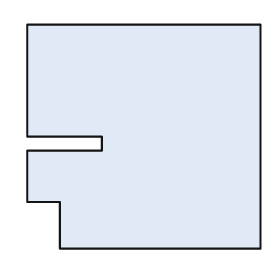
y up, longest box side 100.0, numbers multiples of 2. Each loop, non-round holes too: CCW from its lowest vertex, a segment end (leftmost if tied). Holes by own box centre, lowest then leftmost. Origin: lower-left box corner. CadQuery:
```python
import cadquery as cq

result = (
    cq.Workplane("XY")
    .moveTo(14.0, 0.0)
    .lineTo(100.0, 0.0)
    .lineTo(100.0, 96.0)
    .lineTo(0.0, 96.0)
    .lineTo(0.0, 48.0)
    .lineTo(32.0, 48.0)
    .lineTo(32.0, 42.0)
    .lineTo(0.0, 42.0)
    .lineTo(0.0, 20.0)
    .lineTo(14.0, 20.0)
    .close()
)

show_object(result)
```